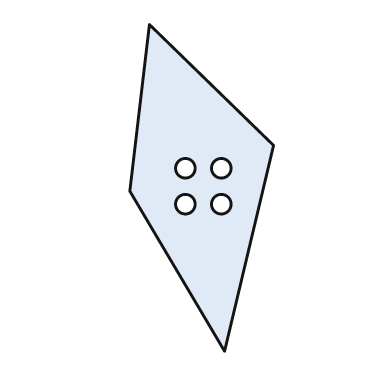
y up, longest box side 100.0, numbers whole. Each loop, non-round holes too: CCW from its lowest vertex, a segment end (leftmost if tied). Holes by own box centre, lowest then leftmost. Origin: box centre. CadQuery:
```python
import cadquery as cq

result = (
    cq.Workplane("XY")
    .moveTo(7.0, -50.0)
    .lineTo(22.0, 13.0)
    .lineTo(-16.0, 50.0)
    .lineTo(-22.0, -1.0)
    .close()
    .moveTo(-5.0, -5.0)
    .circle(3.0)
    .moveTo(6.0, -5.0)
    .circle(3.0)
    .moveTo(-5.0, 6.0)
    .circle(3.0)
    .moveTo(6.0, 6.0)
    .circle(3.0)
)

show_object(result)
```